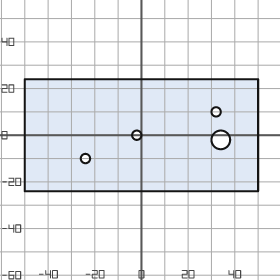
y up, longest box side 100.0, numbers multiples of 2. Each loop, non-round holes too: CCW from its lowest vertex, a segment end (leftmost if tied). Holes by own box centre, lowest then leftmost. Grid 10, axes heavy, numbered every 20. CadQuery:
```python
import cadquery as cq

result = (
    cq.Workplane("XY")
    .moveTo(-50.0, -24.0)
    .lineTo(50.0, -24.0)
    .lineTo(50.0, 24.0)
    .lineTo(-50.0, 24.0)
    .close()
    .moveTo(-24.0, -10.0)
    .circle(2.0)
    .moveTo(34.0, -2.0)
    .circle(4.0)
    .moveTo(-2.0, 0.0)
    .circle(2.0)
    .moveTo(32.0, 10.0)
    .circle(2.0)
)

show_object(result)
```